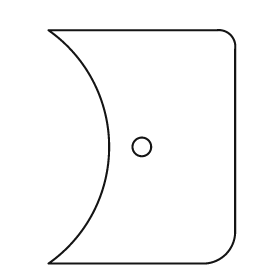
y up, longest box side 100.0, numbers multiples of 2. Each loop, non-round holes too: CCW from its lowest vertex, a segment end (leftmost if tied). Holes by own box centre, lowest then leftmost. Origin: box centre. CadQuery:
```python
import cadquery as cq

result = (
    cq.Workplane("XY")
    .moveTo(-40.0, -50.0)
    .lineTo(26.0, -50.0)
    .threePointArc((36.0, -46.0), (40.0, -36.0))
    .lineTo(40.0, 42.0)
    .threePointArc((38.0, 48.0), (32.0, 50.0))
    .lineTo(-40.0, 50.0)
    .threePointArc((-14.0, 0.0), (-40.0, -50.0))
    .close()
    .moveTo(0.0, 0.0)
    .circle(4.0)
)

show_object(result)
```